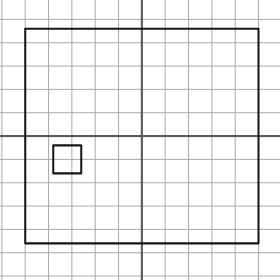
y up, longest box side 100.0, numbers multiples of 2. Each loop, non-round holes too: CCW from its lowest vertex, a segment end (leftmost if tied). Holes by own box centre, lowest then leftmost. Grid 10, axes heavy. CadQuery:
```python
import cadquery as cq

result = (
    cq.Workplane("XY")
    .moveTo(-50.0, -46.0)
    .lineTo(50.0, -46.0)
    .lineTo(50.0, 46.0)
    .lineTo(-50.0, 46.0)
    .close()
    .moveTo(-38.0, -16.0)
    .lineTo(-26.0, -16.0)
    .lineTo(-26.0, -4.0)
    .lineTo(-38.0, -4.0)
    .close()
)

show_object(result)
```